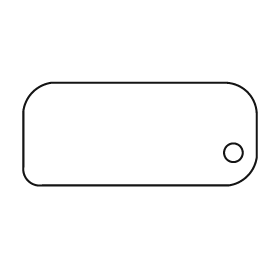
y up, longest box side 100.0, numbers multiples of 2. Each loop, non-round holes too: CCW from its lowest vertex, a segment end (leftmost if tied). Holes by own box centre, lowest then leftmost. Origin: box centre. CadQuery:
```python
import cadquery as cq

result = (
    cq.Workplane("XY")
    .moveTo(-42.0, -22.0)
    .lineTo(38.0, -22.0)
    .threePointArc((46.0, -18.0), (50.0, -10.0))
    .lineTo(50.0, 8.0)
    .threePointArc((46.0, 18.0), (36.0, 22.0))
    .lineTo(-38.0, 22.0)
    .threePointArc((-46.0, 18.0), (-50.0, 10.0))
    .lineTo(-50.0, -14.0)
    .threePointArc((-48.0, -20.0), (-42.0, -22.0))
    .close()
    .moveTo(40.0, -8.0)
    .circle(4.0)
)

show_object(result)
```